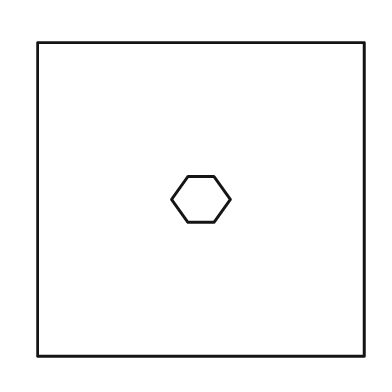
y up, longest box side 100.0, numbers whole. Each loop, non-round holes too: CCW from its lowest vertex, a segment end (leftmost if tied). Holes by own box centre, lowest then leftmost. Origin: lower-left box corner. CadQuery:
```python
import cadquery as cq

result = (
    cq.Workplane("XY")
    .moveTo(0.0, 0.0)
    .lineTo(100.0, 0.0)
    .lineTo(100.0, 96.0)
    .lineTo(0.0, 96.0)
    .close()
    .moveTo(46.0, 41.0)
    .lineTo(54.0, 41.0)
    .lineTo(59.0, 48.0)
    .lineTo(54.0, 55.0)
    .lineTo(46.0, 55.0)
    .lineTo(41.0, 48.0)
    .close()
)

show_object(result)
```